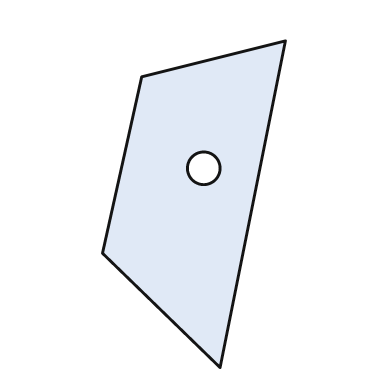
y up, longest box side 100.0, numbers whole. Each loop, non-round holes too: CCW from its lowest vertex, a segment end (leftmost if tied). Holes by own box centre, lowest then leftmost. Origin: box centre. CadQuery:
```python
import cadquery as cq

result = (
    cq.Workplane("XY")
    .moveTo(8.0, -50.0)
    .lineTo(28.0, 50.0)
    .lineTo(-16.0, 39.0)
    .lineTo(-28.0, -15.0)
    .close()
    .moveTo(3.0, 11.0)
    .circle(5.0)
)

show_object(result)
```